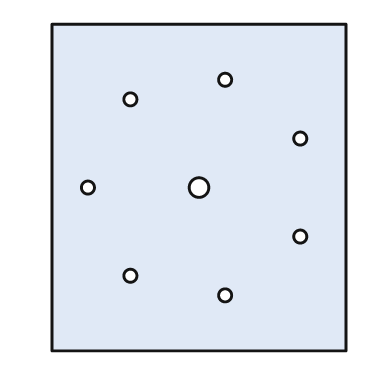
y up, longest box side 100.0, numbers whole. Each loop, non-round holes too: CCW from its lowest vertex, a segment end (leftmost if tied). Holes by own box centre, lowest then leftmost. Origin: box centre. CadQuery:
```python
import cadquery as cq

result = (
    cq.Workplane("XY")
    .moveTo(-45.0, -50.0)
    .lineTo(45.0, -50.0)
    .lineTo(45.0, 50.0)
    .lineTo(-45.0, 50.0)
    .close()
    .moveTo(8.0, -33.0)
    .circle(2.0)
    .moveTo(-21.0, -27.0)
    .circle(2.0)
    .moveTo(31.0, -15.0)
    .circle(2.0)
    .moveTo(-34.0, 0.0)
    .circle(2.0)
    .moveTo(0.0, 0.0)
    .circle(3.0)
    .moveTo(31.0, 15.0)
    .circle(2.0)
    .moveTo(-21.0, 27.0)
    .circle(2.0)
    .moveTo(8.0, 33.0)
    .circle(2.0)
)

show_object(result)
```